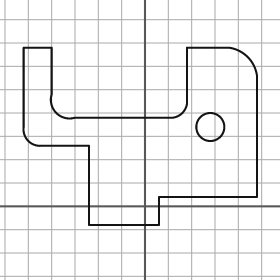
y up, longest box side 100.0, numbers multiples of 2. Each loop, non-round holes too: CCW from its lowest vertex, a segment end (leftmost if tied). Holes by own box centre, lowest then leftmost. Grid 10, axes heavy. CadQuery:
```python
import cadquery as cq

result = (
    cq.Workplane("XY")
    .moveTo(-24.0, -8.0)
    .lineTo(6.0, -8.0)
    .lineTo(6.0, 4.0)
    .lineTo(48.0, 4.0)
    .lineTo(48.0, 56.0)
    .threePointArc((44.0, 64.0), (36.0, 68.0))
    .lineTo(18.0, 68.0)
    .lineTo(18.0, 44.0)
    .threePointArc((16.0, 40.0), (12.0, 38.0))
    .lineTo(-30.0, 38.0)
    .threePointArc((-38.0, 40.0), (-40.0, 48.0))
    .lineTo(-40.0, 68.0)
    .lineTo(-52.0, 68.0)
    .lineTo(-52.0, 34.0)
    .threePointArc((-50.0, 28.0), (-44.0, 26.0))
    .lineTo(-24.0, 26.0)
    .close()
    .moveTo(28.0, 34.0)
    .circle(6.0)
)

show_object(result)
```